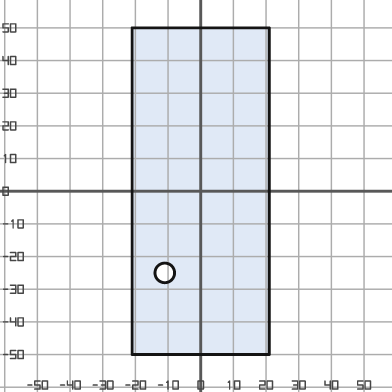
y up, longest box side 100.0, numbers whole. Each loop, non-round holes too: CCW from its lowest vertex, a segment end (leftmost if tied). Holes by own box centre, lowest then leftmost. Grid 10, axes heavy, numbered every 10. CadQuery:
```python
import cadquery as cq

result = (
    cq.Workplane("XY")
    .moveTo(-21.0, -50.0)
    .lineTo(21.0, -50.0)
    .lineTo(21.0, 50.0)
    .lineTo(-21.0, 50.0)
    .close()
    .moveTo(-11.0, -25.0)
    .circle(3.0)
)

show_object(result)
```